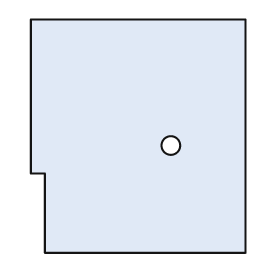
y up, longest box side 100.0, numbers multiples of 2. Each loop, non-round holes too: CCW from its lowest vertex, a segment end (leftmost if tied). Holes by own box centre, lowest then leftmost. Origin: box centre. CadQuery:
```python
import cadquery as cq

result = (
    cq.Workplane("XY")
    .moveTo(-40.0, -50.0)
    .lineTo(46.0, -50.0)
    .lineTo(46.0, 50.0)
    .lineTo(-46.0, 50.0)
    .lineTo(-46.0, -16.0)
    .lineTo(-40.0, -16.0)
    .close()
    .moveTo(14.0, -4.0)
    .circle(4.0)
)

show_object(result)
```